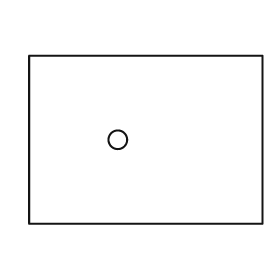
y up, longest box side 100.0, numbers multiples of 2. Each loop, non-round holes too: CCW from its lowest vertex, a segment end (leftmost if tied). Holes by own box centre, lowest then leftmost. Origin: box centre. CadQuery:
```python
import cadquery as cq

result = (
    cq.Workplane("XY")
    .moveTo(-50.0, -36.0)
    .lineTo(50.0, -36.0)
    .lineTo(50.0, 36.0)
    .lineTo(-50.0, 36.0)
    .close()
    .moveTo(-12.0, 0.0)
    .circle(4.0)
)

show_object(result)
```